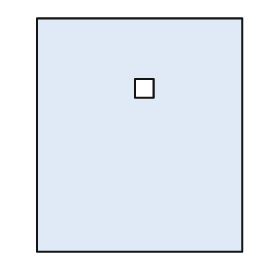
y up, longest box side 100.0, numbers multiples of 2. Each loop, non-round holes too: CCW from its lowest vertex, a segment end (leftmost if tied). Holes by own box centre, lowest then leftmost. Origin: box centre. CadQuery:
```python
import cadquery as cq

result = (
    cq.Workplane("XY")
    .moveTo(-44.0, -50.0)
    .lineTo(44.0, -50.0)
    .lineTo(44.0, 50.0)
    .lineTo(-44.0, 50.0)
    .close()
    .moveTo(-2.0, 16.0)
    .lineTo(6.0, 16.0)
    .lineTo(6.0, 24.0)
    .lineTo(-2.0, 24.0)
    .close()
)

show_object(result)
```